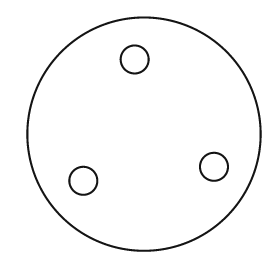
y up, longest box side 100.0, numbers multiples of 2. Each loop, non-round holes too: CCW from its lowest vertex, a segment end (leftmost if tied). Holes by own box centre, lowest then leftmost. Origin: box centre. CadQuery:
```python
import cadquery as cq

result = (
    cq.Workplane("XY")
    .moveTo(0.0, 0.0)
    .circle(50.0)
    .moveTo(-26.0, -20.0)
    .circle(6.0)
    .moveTo(30.0, -14.0)
    .circle(6.0)
    .moveTo(-4.0, 32.0)
    .circle(6.0)
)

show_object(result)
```